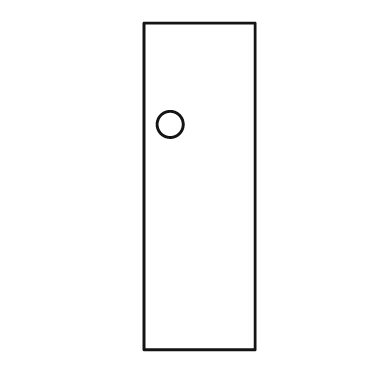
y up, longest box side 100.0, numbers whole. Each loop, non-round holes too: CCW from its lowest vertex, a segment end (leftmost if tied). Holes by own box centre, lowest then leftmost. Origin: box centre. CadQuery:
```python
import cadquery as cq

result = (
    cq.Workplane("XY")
    .moveTo(-17.0, -50.0)
    .lineTo(17.0, -50.0)
    .lineTo(17.0, 50.0)
    .lineTo(-17.0, 50.0)
    .close()
    .moveTo(-9.0, 19.0)
    .circle(4.0)
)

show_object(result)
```